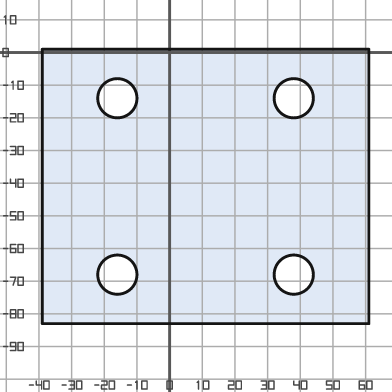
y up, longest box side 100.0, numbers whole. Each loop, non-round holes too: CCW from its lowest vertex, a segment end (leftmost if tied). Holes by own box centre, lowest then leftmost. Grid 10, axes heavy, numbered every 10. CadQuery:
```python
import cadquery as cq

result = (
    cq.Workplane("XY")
    .moveTo(-39.0, -83.0)
    .lineTo(61.0, -83.0)
    .lineTo(61.0, 1.0)
    .lineTo(-39.0, 1.0)
    .close()
    .moveTo(-16.0, -68.0)
    .circle(6.0)
    .moveTo(38.0, -68.0)
    .circle(6.0)
    .moveTo(-16.0, -14.0)
    .circle(6.0)
    .moveTo(38.0, -14.0)
    .circle(6.0)
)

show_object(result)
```